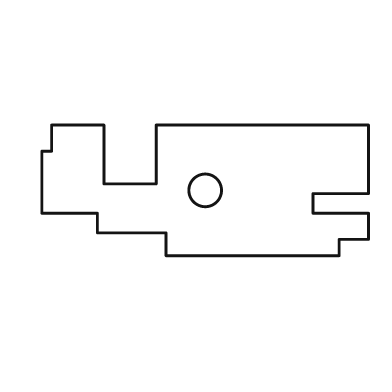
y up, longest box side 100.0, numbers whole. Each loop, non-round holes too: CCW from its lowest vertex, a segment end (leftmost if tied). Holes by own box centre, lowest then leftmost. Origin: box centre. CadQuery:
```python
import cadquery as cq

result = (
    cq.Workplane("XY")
    .moveTo(-12.0, -20.0)
    .lineTo(41.0, -20.0)
    .lineTo(41.0, -15.0)
    .lineTo(50.0, -15.0)
    .lineTo(50.0, -7.0)
    .lineTo(33.0, -7.0)
    .lineTo(33.0, -1.0)
    .lineTo(50.0, -1.0)
    .lineTo(50.0, 20.0)
    .lineTo(-15.0, 20.0)
    .lineTo(-15.0, 2.0)
    .lineTo(-31.0, 2.0)
    .lineTo(-31.0, 20.0)
    .lineTo(-47.0, 20.0)
    .lineTo(-47.0, 12.0)
    .lineTo(-50.0, 12.0)
    .lineTo(-50.0, -7.0)
    .lineTo(-33.0, -7.0)
    .lineTo(-33.0, -13.0)
    .lineTo(-12.0, -13.0)
    .close()
    .moveTo(0.0, 0.0)
    .circle(5.0)
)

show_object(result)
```